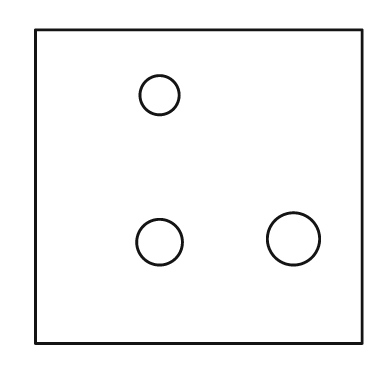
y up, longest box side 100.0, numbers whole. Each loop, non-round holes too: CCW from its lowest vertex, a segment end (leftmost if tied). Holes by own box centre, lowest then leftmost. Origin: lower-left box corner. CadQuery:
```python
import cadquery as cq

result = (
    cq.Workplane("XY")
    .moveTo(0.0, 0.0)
    .lineTo(100.0, 0.0)
    .lineTo(100.0, 96.0)
    .lineTo(0.0, 96.0)
    .close()
    .moveTo(38.0, 31.0)
    .circle(7.0)
    .moveTo(79.0, 32.0)
    .circle(8.0)
    .moveTo(38.0, 76.0)
    .circle(6.0)
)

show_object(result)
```